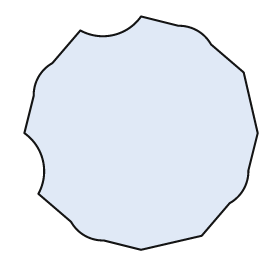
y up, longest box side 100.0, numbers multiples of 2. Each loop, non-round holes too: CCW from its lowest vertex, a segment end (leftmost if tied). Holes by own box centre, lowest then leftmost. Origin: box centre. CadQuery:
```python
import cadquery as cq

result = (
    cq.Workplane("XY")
    .moveTo(0.0, -50.0)
    .lineTo(26.0, -44.0)
    .lineTo(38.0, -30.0)
    .threePointArc((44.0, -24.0), (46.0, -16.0))
    .lineTo(50.0, 0.0)
    .lineTo(44.0, 26.0)
    .lineTo(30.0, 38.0)
    .threePointArc((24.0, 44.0), (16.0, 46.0))
    .lineTo(0.0, 50.0)
    .threePointArc((-12.0, 42.0), (-26.0, 44.0))
    .lineTo(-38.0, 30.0)
    .threePointArc((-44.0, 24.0), (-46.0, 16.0))
    .lineTo(-50.0, 0.0)
    .threePointArc((-42.0, -12.0), (-44.0, -26.0))
    .lineTo(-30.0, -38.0)
    .threePointArc((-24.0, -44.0), (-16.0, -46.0))
    .close()
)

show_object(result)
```